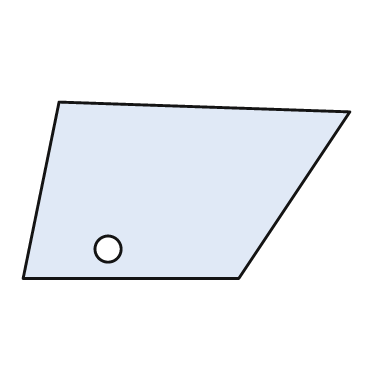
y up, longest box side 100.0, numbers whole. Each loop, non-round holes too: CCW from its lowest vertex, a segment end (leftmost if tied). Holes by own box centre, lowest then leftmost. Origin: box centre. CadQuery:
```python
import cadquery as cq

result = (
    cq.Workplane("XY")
    .moveTo(-50.0, -27.0)
    .lineTo(16.0, -27.0)
    .lineTo(50.0, 24.0)
    .lineTo(-39.0, 27.0)
    .close()
    .moveTo(-24.0, -18.0)
    .circle(4.0)
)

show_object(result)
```